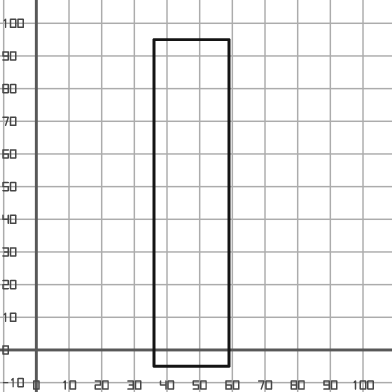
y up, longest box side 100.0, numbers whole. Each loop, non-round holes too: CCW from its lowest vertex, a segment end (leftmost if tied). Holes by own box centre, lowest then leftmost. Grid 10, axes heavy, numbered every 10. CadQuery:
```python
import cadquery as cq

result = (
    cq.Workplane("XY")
    .moveTo(36.0, -5.0)
    .lineTo(59.0, -5.0)
    .lineTo(59.0, 95.0)
    .lineTo(36.0, 95.0)
    .close()
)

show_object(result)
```